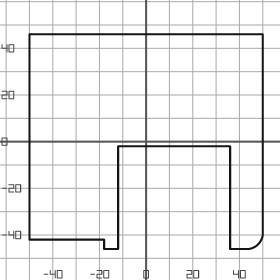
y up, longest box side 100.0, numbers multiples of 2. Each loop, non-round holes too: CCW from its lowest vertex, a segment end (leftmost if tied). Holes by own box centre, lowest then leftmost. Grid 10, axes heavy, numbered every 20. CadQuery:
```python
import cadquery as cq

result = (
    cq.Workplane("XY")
    .moveTo(-18.0, -46.0)
    .lineTo(-12.0, -46.0)
    .lineTo(-12.0, -2.0)
    .lineTo(36.0, -2.0)
    .lineTo(36.0, -46.0)
    .lineTo(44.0, -46.0)
    .threePointArc((48.0, -44.0), (50.0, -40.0))
    .lineTo(50.0, 46.0)
    .lineTo(-50.0, 46.0)
    .lineTo(-50.0, -42.0)
    .lineTo(-18.0, -42.0)
    .close()
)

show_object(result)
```